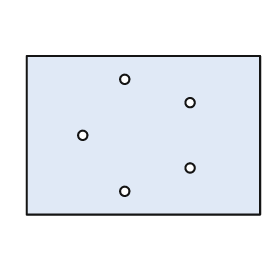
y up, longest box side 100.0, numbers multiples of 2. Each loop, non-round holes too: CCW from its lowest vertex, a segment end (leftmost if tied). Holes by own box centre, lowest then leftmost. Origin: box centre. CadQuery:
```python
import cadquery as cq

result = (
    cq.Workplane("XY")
    .moveTo(-50.0, -34.0)
    .lineTo(50.0, -34.0)
    .lineTo(50.0, 34.0)
    .lineTo(-50.0, 34.0)
    .close()
    .moveTo(-8.0, -24.0)
    .circle(2.0)
    .moveTo(20.0, -14.0)
    .circle(2.0)
    .moveTo(-26.0, 0.0)
    .circle(2.0)
    .moveTo(20.0, 14.0)
    .circle(2.0)
    .moveTo(-8.0, 24.0)
    .circle(2.0)
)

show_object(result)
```